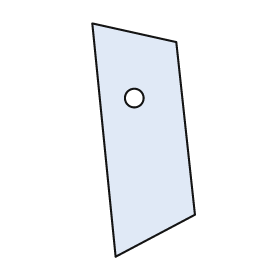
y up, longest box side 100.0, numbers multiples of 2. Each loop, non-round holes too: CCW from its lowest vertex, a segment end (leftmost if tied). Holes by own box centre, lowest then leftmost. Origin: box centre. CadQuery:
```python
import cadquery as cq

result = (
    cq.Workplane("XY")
    .moveTo(-12.0, -50.0)
    .lineTo(22.0, -32.0)
    .lineTo(14.0, 42.0)
    .lineTo(-22.0, 50.0)
    .close()
    .moveTo(-4.0, 18.0)
    .circle(4.0)
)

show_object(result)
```